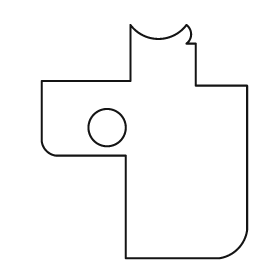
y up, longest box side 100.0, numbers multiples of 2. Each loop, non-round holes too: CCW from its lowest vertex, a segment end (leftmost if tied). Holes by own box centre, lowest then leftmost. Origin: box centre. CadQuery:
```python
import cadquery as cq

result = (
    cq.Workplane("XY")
    .moveTo(-8.0, -50.0)
    .lineTo(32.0, -50.0)
    .threePointArc((40.0, -46.0), (44.0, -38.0))
    .lineTo(44.0, 24.0)
    .lineTo(22.0, 24.0)
    .lineTo(22.0, 42.0)
    .lineTo(18.0, 42.0)
    .threePointArc((20.0, 46.0), (18.0, 50.0))
    .threePointArc((6.0, 44.0), (-6.0, 50.0))
    .lineTo(-6.0, 26.0)
    .lineTo(-44.0, 26.0)
    .lineTo(-44.0, 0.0)
    .threePointArc((-42.0, -4.0), (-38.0, -6.0))
    .lineTo(-8.0, -6.0)
    .close()
    .moveTo(-16.0, 6.0)
    .circle(8.0)
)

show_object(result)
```